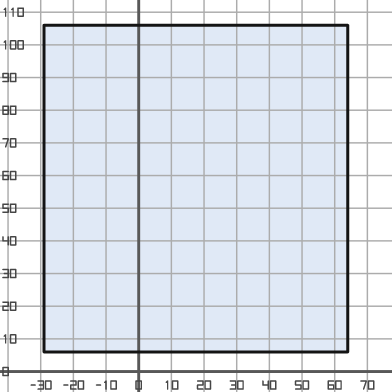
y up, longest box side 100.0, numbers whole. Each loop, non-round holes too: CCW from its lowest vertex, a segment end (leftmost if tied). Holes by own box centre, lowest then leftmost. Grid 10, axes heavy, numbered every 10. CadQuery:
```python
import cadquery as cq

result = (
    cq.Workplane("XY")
    .moveTo(-29.0, 6.0)
    .lineTo(64.0, 6.0)
    .lineTo(64.0, 106.0)
    .lineTo(-29.0, 106.0)
    .close()
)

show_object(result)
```